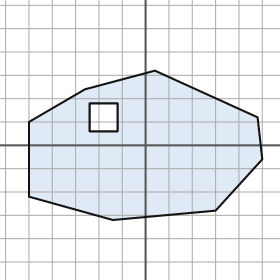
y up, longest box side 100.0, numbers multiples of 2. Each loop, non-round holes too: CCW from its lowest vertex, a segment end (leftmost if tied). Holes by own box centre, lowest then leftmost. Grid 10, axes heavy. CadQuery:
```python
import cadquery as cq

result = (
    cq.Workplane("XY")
    .moveTo(-14.0, -32.0)
    .lineTo(30.0, -28.0)
    .lineTo(50.0, -6.0)
    .lineTo(48.0, 12.0)
    .lineTo(4.0, 32.0)
    .lineTo(-26.0, 24.0)
    .lineTo(-50.0, 10.0)
    .lineTo(-50.0, -22.0)
    .close()
    .moveTo(-24.0, 6.0)
    .lineTo(-12.0, 6.0)
    .lineTo(-12.0, 18.0)
    .lineTo(-24.0, 18.0)
    .close()
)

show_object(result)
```